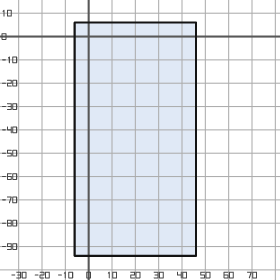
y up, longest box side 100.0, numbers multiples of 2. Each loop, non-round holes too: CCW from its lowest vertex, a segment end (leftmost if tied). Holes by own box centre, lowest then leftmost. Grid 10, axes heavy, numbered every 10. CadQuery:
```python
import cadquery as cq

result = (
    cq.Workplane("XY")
    .moveTo(-6.0, -94.0)
    .lineTo(46.0, -94.0)
    .lineTo(46.0, 6.0)
    .lineTo(-6.0, 6.0)
    .close()
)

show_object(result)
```